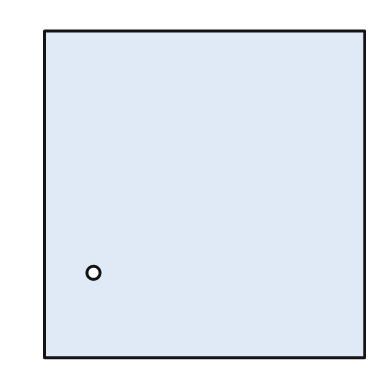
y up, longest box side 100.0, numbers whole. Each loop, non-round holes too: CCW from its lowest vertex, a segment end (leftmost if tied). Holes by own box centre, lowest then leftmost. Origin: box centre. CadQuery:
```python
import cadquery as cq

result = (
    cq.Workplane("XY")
    .moveTo(-49.0, -50.0)
    .lineTo(49.0, -50.0)
    .lineTo(49.0, 50.0)
    .lineTo(-49.0, 50.0)
    .close()
    .moveTo(-34.0, -24.0)
    .circle(2.0)
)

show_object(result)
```